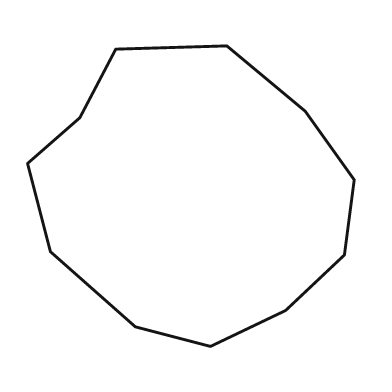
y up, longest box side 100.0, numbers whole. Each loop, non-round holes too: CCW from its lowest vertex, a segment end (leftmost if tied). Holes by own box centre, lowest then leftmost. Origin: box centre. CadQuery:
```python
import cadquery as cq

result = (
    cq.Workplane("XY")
    .moveTo(6.0, -46.0)
    .lineTo(29.0, -35.0)
    .lineTo(47.0, -18.0)
    .lineTo(50.0, 5.0)
    .lineTo(35.0, 26.0)
    .lineTo(11.0, 46.0)
    .lineTo(-23.0, 45.0)
    .lineTo(-34.0, 24.0)
    .lineTo(-50.0, 10.0)
    .lineTo(-43.0, -17.0)
    .lineTo(-17.0, -40.0)
    .close()
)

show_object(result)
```